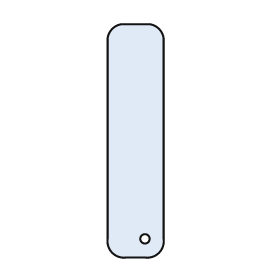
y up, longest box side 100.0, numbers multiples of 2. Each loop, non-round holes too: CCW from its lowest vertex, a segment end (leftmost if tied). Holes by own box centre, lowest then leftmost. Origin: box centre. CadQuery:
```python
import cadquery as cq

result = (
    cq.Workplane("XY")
    .moveTo(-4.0, -50.0)
    .lineTo(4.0, -50.0)
    .threePointArc((10.0, -48.0), (12.0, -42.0))
    .lineTo(12.0, 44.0)
    .threePointArc((10.0, 48.0), (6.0, 50.0))
    .lineTo(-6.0, 50.0)
    .threePointArc((-10.0, 48.0), (-12.0, 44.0))
    .lineTo(-12.0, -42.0)
    .threePointArc((-10.0, -48.0), (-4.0, -50.0))
    .close()
    .moveTo(4.0, -42.0)
    .circle(2.0)
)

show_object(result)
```